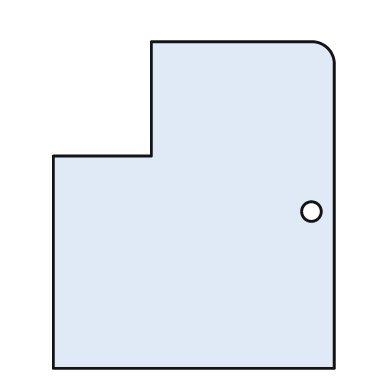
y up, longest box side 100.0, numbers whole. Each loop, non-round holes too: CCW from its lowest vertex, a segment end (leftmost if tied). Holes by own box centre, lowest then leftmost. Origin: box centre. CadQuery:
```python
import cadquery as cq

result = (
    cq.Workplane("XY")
    .moveTo(-43.0, -50.0)
    .lineTo(43.0, -50.0)
    .lineTo(43.0, 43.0)
    .threePointArc((41.0, 48.0), (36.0, 50.0))
    .lineTo(-13.0, 50.0)
    .lineTo(-13.0, 15.0)
    .lineTo(-43.0, 15.0)
    .close()
    .moveTo(36.0, -2.0)
    .circle(3.0)
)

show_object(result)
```